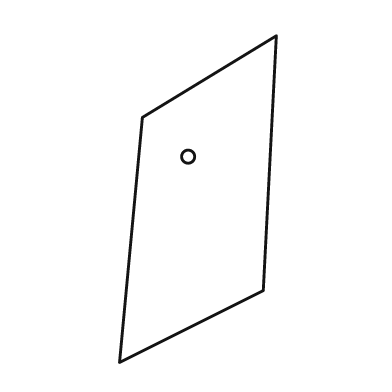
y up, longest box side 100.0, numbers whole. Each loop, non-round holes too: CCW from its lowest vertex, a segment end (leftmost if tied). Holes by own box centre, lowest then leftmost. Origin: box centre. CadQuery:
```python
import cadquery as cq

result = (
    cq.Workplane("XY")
    .moveTo(-24.0, -50.0)
    .lineTo(20.0, -28.0)
    .lineTo(24.0, 50.0)
    .lineTo(-17.0, 25.0)
    .close()
    .moveTo(-3.0, 13.0)
    .circle(2.0)
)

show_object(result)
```